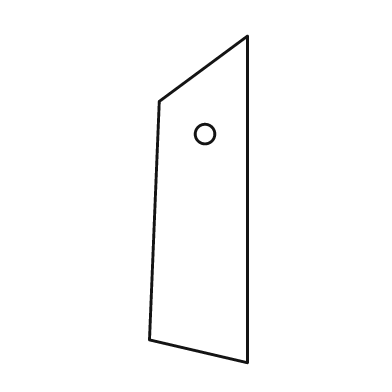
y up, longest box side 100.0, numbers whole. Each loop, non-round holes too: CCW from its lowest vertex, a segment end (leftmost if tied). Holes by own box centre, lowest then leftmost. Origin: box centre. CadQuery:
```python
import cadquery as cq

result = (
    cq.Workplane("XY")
    .moveTo(15.0, -50.0)
    .lineTo(15.0, 50.0)
    .lineTo(-12.0, 30.0)
    .lineTo(-15.0, -43.0)
    .close()
    .moveTo(2.0, 20.0)
    .circle(3.0)
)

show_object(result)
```